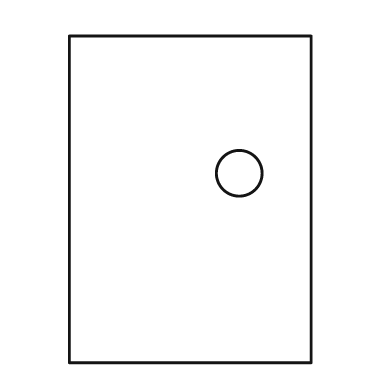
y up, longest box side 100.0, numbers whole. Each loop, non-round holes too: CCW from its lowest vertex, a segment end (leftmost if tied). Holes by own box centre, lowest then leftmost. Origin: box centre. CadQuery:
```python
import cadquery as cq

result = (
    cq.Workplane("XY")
    .moveTo(-37.0, -50.0)
    .lineTo(37.0, -50.0)
    .lineTo(37.0, 50.0)
    .lineTo(-37.0, 50.0)
    .close()
    .moveTo(15.0, 8.0)
    .circle(7.0)
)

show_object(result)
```